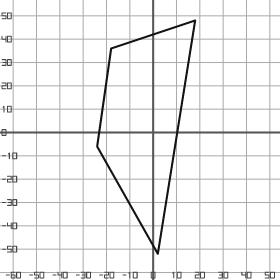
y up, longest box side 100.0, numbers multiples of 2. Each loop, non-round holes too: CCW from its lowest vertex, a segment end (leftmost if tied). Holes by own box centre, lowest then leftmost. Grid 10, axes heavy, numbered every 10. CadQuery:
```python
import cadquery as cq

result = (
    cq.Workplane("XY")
    .moveTo(2.0, -52.0)
    .lineTo(18.0, 48.0)
    .lineTo(-18.0, 36.0)
    .lineTo(-24.0, -6.0)
    .close()
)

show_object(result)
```